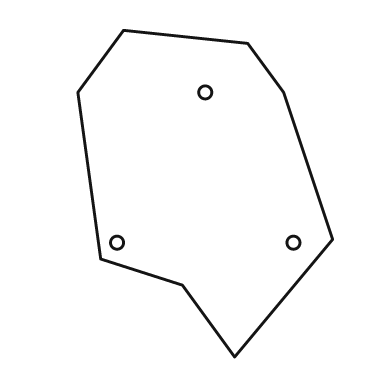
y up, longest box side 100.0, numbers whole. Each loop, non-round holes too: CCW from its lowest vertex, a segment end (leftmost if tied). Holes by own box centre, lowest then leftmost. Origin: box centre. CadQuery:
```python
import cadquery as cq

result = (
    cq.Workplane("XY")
    .moveTo(9.0, -50.0)
    .lineTo(39.0, -14.0)
    .lineTo(24.0, 31.0)
    .lineTo(13.0, 46.0)
    .lineTo(-25.0, 50.0)
    .lineTo(-39.0, 31.0)
    .lineTo(-32.0, -20.0)
    .lineTo(-7.0, -28.0)
    .close()
    .moveTo(-27.0, -15.0)
    .circle(2.0)
    .moveTo(27.0, -15.0)
    .circle(2.0)
    .moveTo(0.0, 31.0)
    .circle(2.0)
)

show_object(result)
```